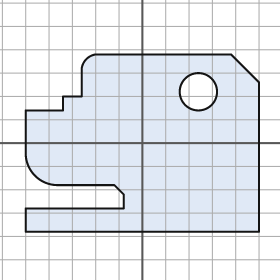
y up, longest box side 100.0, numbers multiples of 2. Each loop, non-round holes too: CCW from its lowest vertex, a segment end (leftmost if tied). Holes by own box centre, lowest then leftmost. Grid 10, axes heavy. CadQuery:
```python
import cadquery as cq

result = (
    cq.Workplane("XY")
    .moveTo(-50.0, -38.0)
    .lineTo(50.0, -38.0)
    .lineTo(50.0, 26.0)
    .lineTo(38.0, 38.0)
    .lineTo(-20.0, 38.0)
    .threePointArc((-24.0, 36.0), (-26.0, 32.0))
    .lineTo(-26.0, 20.0)
    .lineTo(-34.0, 20.0)
    .lineTo(-34.0, 14.0)
    .lineTo(-50.0, 14.0)
    .lineTo(-50.0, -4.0)
    .threePointArc((-46.0, -14.0), (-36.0, -18.0))
    .lineTo(-12.0, -18.0)
    .lineTo(-8.0, -22.0)
    .lineTo(-8.0, -28.0)
    .lineTo(-50.0, -28.0)
    .close()
    .moveTo(24.0, 22.0)
    .circle(8.0)
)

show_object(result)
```